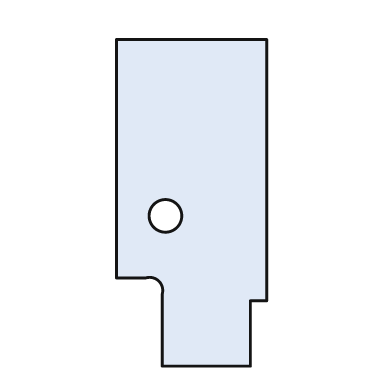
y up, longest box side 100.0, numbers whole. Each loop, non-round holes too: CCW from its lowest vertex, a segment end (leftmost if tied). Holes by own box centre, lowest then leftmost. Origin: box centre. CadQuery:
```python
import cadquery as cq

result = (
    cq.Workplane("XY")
    .moveTo(-9.0, -50.0)
    .lineTo(18.0, -50.0)
    .lineTo(18.0, -30.0)
    .lineTo(23.0, -30.0)
    .lineTo(23.0, 50.0)
    .lineTo(-23.0, 50.0)
    .lineTo(-23.0, -23.0)
    .lineTo(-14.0, -23.0)
    .threePointArc((-10.0, -24.0), (-9.0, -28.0))
    .close()
    .moveTo(-8.0, -4.0)
    .circle(5.0)
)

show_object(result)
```